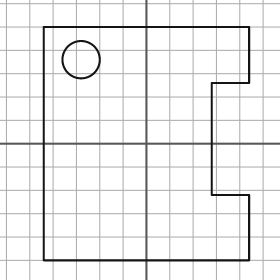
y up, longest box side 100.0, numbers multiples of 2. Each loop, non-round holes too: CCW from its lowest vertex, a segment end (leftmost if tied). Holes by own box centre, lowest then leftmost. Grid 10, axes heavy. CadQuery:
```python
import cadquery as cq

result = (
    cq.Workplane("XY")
    .moveTo(-44.0, -50.0)
    .lineTo(44.0, -50.0)
    .lineTo(44.0, -22.0)
    .lineTo(28.0, -22.0)
    .lineTo(28.0, 26.0)
    .lineTo(44.0, 26.0)
    .lineTo(44.0, 50.0)
    .lineTo(-44.0, 50.0)
    .close()
    .moveTo(-28.0, 36.0)
    .circle(8.0)
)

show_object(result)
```